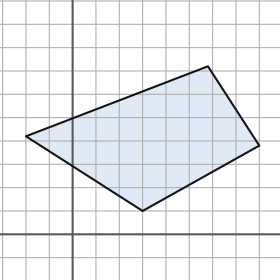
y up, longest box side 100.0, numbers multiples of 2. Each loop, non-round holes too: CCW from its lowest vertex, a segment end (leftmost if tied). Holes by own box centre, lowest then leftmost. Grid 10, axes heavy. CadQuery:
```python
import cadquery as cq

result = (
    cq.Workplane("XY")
    .moveTo(30.0, 10.0)
    .lineTo(80.0, 38.0)
    .lineTo(58.0, 72.0)
    .lineTo(-20.0, 42.0)
    .close()
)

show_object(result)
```